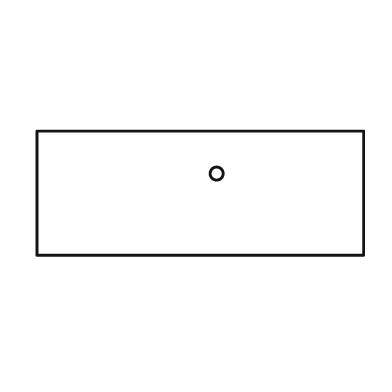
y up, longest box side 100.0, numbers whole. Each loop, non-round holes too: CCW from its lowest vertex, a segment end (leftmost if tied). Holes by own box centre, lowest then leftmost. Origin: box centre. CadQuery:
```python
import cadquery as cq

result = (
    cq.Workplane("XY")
    .moveTo(-50.0, -19.0)
    .lineTo(50.0, -19.0)
    .lineTo(50.0, 19.0)
    .lineTo(-50.0, 19.0)
    .close()
    .moveTo(5.0, 6.0)
    .circle(2.0)
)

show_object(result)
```